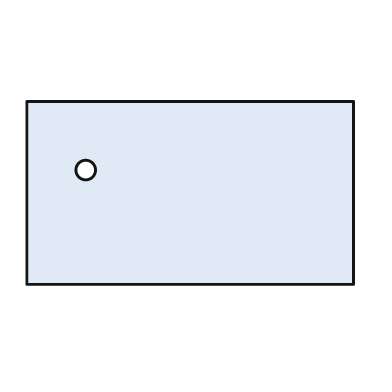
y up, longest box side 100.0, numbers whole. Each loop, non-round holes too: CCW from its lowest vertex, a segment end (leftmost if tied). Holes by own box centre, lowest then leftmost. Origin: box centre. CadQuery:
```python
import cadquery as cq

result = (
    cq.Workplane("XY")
    .moveTo(-50.0, -28.0)
    .lineTo(50.0, -28.0)
    .lineTo(50.0, 28.0)
    .lineTo(-50.0, 28.0)
    .close()
    .moveTo(-32.0, 7.0)
    .circle(3.0)
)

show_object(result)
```